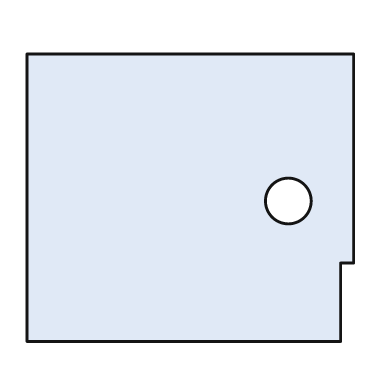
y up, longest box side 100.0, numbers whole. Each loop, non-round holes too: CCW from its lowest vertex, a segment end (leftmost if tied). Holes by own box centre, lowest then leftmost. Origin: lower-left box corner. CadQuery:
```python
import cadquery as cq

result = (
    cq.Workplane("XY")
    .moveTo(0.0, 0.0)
    .lineTo(96.0, 0.0)
    .lineTo(96.0, 24.0)
    .lineTo(100.0, 24.0)
    .lineTo(100.0, 88.0)
    .lineTo(0.0, 88.0)
    .close()
    .moveTo(80.0, 43.0)
    .circle(7.0)
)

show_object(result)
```